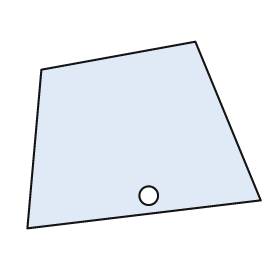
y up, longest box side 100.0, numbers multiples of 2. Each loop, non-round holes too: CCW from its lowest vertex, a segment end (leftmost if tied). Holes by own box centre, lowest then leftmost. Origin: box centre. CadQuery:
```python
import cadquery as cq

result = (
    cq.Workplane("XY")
    .moveTo(-50.0, -40.0)
    .lineTo(50.0, -28.0)
    .lineTo(22.0, 40.0)
    .lineTo(-44.0, 28.0)
    .close()
    .moveTo(2.0, -26.0)
    .circle(4.0)
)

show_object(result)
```